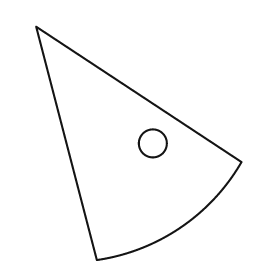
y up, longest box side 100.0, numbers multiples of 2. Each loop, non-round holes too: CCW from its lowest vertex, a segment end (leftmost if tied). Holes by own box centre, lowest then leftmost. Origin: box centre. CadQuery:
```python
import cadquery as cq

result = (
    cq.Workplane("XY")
    .moveTo(-18.0, -50.0)
    .threePointArc((18.0, -36.0), (44.0, -8.0))
    .lineTo(-44.0, 50.0)
    .close()
    .moveTo(6.0, 0.0)
    .circle(6.0)
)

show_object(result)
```